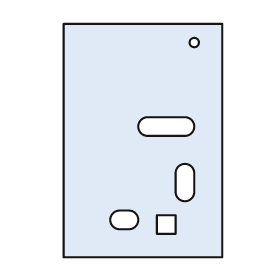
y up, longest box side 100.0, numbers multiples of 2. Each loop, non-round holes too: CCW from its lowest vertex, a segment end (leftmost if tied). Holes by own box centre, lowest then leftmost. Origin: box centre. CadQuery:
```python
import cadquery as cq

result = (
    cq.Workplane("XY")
    .moveTo(-34.0, -50.0)
    .lineTo(34.0, -50.0)
    .lineTo(34.0, 50.0)
    .lineTo(-34.0, 50.0)
    .close()
    .moveTo(6.0, -40.0)
    .lineTo(14.0, -40.0)
    .lineTo(14.0, -32.0)
    .lineTo(6.0, -32.0)
    .close()
    .moveTo(-10.0, -38.0)
    .lineTo(-6.0, -38.0)
    .threePointArc((-2.0, -34.0), (-6.0, -30.0))
    .lineTo(-10.0, -30.0)
    .threePointArc((-14.0, -34.0), (-10.0, -38.0))
    .close()
    .moveTo(14.0, -22.0)
    .threePointArc((18.0, -26.0), (22.0, -22.0))
    .lineTo(22.0, -14.0)
    .threePointArc((18.0, -10.0), (14.0, -14.0))
    .close()
    .moveTo(2.0, 2.0)
    .lineTo(18.0, 2.0)
    .threePointArc((22.0, 6.0), (18.0, 10.0))
    .lineTo(2.0, 10.0)
    .threePointArc((-2.0, 6.0), (2.0, 2.0))
    .close()
    .moveTo(22.0, 42.0)
    .circle(2.0)
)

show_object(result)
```